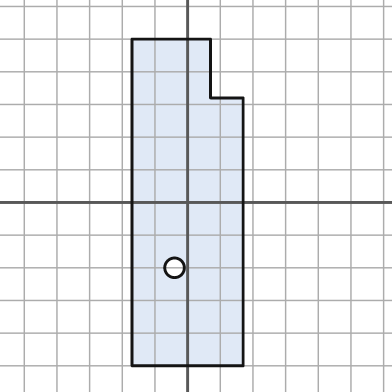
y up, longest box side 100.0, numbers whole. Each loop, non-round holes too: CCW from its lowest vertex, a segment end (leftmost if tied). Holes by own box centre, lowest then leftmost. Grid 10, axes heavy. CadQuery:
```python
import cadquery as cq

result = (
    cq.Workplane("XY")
    .moveTo(-17.0, -50.0)
    .lineTo(17.0, -50.0)
    .lineTo(17.0, 32.0)
    .lineTo(7.0, 32.0)
    .lineTo(7.0, 50.0)
    .lineTo(-17.0, 50.0)
    .close()
    .moveTo(-4.0, -20.0)
    .circle(3.0)
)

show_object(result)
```